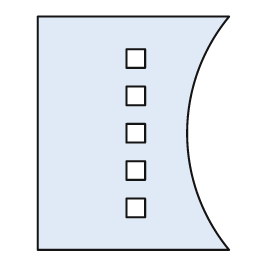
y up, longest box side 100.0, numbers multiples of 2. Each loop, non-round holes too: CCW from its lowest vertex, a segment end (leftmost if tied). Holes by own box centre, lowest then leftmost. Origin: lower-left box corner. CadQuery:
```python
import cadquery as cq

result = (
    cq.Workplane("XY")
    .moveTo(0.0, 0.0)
    .lineTo(82.0, 0.0)
    .threePointArc((64.0, 50.0), (82.0, 100.0))
    .lineTo(0.0, 100.0)
    .close()
    .moveTo(38.0, 14.0)
    .lineTo(46.0, 14.0)
    .lineTo(46.0, 22.0)
    .lineTo(38.0, 22.0)
    .close()
    .moveTo(38.0, 30.0)
    .lineTo(46.0, 30.0)
    .lineTo(46.0, 38.0)
    .lineTo(38.0, 38.0)
    .close()
    .moveTo(38.0, 46.0)
    .lineTo(46.0, 46.0)
    .lineTo(46.0, 54.0)
    .lineTo(38.0, 54.0)
    .close()
    .moveTo(38.0, 62.0)
    .lineTo(46.0, 62.0)
    .lineTo(46.0, 70.0)
    .lineTo(38.0, 70.0)
    .close()
    .moveTo(38.0, 78.0)
    .lineTo(46.0, 78.0)
    .lineTo(46.0, 86.0)
    .lineTo(38.0, 86.0)
    .close()
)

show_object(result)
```